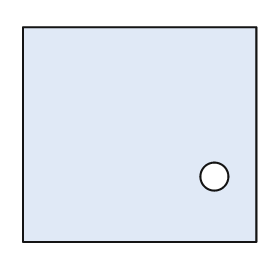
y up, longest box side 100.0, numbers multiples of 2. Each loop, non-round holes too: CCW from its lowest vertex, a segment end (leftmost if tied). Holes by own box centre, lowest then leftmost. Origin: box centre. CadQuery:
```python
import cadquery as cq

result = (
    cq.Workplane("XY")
    .moveTo(-50.0, -46.0)
    .lineTo(50.0, -46.0)
    .lineTo(50.0, 46.0)
    .lineTo(-50.0, 46.0)
    .close()
    .moveTo(32.0, -18.0)
    .circle(6.0)
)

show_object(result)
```